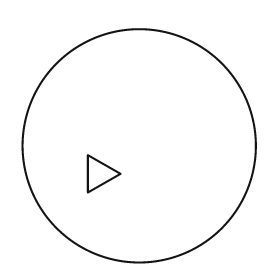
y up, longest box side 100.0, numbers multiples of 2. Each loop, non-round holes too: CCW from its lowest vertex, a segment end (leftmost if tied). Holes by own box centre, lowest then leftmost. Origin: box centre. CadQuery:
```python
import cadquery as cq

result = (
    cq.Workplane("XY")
    .moveTo(0.0, 0.0)
    .circle(50.0)
    .moveTo(-22.0, -20.0)
    .lineTo(-8.0, -12.0)
    .lineTo(-22.0, -4.0)
    .close()
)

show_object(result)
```